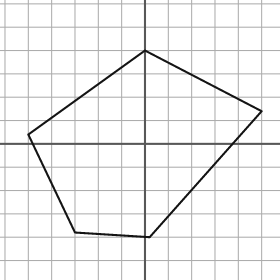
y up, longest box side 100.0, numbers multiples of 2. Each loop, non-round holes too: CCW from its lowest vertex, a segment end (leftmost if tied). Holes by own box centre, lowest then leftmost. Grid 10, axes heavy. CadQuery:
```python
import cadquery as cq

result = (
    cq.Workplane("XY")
    .moveTo(2.0, -40.0)
    .lineTo(50.0, 14.0)
    .lineTo(0.0, 40.0)
    .lineTo(-50.0, 4.0)
    .lineTo(-30.0, -38.0)
    .close()
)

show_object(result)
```